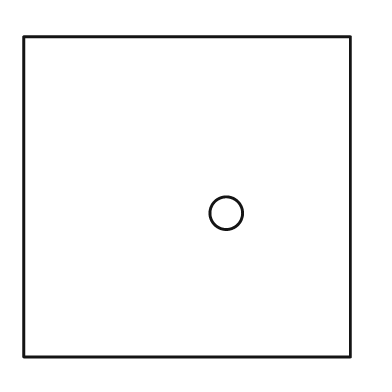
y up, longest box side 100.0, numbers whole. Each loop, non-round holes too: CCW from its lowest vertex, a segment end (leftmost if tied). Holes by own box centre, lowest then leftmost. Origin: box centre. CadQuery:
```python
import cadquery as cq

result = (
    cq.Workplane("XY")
    .moveTo(-50.0, -49.0)
    .lineTo(50.0, -49.0)
    .lineTo(50.0, 49.0)
    .lineTo(-50.0, 49.0)
    .close()
    .moveTo(12.0, -5.0)
    .circle(5.0)
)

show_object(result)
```